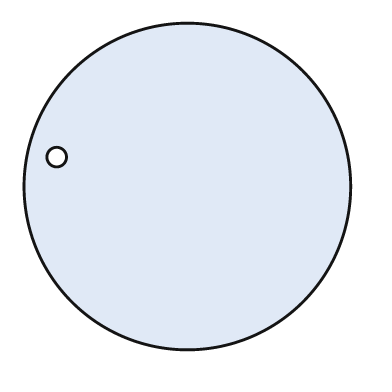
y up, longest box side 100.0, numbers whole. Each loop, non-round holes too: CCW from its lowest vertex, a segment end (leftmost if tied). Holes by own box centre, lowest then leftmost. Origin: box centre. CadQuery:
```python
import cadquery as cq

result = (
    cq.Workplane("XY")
    .moveTo(0.0, 0.0)
    .circle(50.0)
    .moveTo(-40.0, 9.0)
    .circle(3.0)
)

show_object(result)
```